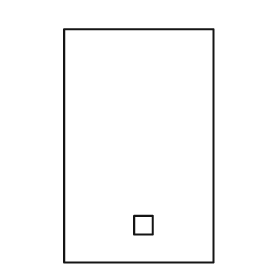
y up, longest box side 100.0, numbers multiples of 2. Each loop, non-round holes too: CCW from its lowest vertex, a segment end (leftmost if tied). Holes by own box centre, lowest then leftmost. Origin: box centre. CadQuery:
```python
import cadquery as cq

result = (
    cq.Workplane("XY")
    .moveTo(-32.0, -50.0)
    .lineTo(32.0, -50.0)
    .lineTo(32.0, 50.0)
    .lineTo(-32.0, 50.0)
    .close()
    .moveTo(-2.0, -38.0)
    .lineTo(6.0, -38.0)
    .lineTo(6.0, -30.0)
    .lineTo(-2.0, -30.0)
    .close()
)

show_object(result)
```